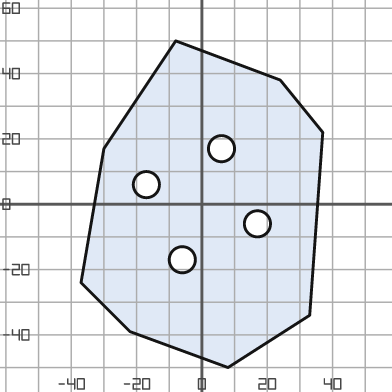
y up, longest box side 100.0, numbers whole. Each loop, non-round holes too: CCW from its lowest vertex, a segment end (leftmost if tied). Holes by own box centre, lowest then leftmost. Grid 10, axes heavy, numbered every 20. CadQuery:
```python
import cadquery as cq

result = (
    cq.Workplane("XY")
    .moveTo(8.0, -50.0)
    .lineTo(33.0, -34.0)
    .lineTo(37.0, 22.0)
    .lineTo(24.0, 38.0)
    .lineTo(-8.0, 50.0)
    .lineTo(-30.0, 17.0)
    .lineTo(-37.0, -24.0)
    .lineTo(-22.0, -39.0)
    .close()
    .moveTo(-6.0, -17.0)
    .circle(4.0)
    .moveTo(17.0, -6.0)
    .circle(4.0)
    .moveTo(-17.0, 6.0)
    .circle(4.0)
    .moveTo(6.0, 17.0)
    .circle(4.0)
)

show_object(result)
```